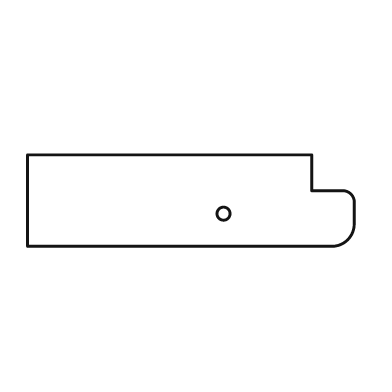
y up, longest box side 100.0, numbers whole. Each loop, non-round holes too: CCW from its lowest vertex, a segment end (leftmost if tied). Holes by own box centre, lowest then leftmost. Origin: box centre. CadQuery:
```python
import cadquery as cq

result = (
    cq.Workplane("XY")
    .moveTo(-50.0, -14.0)
    .lineTo(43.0, -14.0)
    .threePointArc((48.0, -12.0), (50.0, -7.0))
    .lineTo(50.0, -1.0)
    .threePointArc((49.0, 2.0), (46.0, 3.0))
    .lineTo(37.0, 3.0)
    .lineTo(37.0, 14.0)
    .lineTo(-50.0, 14.0)
    .close()
    .moveTo(10.0, -4.0)
    .circle(2.0)
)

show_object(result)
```